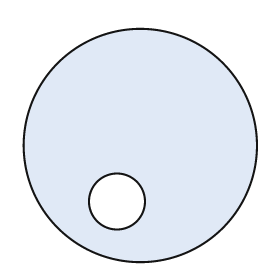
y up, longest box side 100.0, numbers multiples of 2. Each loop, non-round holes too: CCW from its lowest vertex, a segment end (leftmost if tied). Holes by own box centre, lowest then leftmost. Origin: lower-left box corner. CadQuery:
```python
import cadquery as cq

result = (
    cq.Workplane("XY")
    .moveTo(50.0, 50.0)
    .circle(50.0)
    .moveTo(40.0, 26.0)
    .circle(12.0)
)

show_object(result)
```